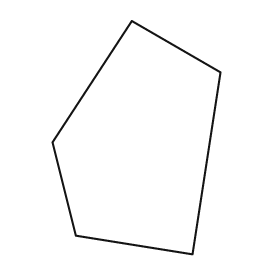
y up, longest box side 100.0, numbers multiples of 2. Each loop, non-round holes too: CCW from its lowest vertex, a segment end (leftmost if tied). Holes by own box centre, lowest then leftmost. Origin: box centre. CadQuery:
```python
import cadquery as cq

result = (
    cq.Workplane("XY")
    .moveTo(24.0, -50.0)
    .lineTo(36.0, 28.0)
    .lineTo(-2.0, 50.0)
    .lineTo(-36.0, -2.0)
    .lineTo(-26.0, -42.0)
    .close()
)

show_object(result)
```